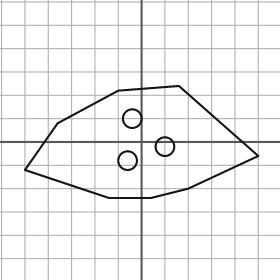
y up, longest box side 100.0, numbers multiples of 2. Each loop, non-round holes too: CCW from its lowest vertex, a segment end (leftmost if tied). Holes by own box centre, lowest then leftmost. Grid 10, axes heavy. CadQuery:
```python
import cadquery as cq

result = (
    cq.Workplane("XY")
    .moveTo(-14.0, -24.0)
    .lineTo(4.0, -24.0)
    .lineTo(20.0, -20.0)
    .lineTo(50.0, -6.0)
    .lineTo(16.0, 24.0)
    .lineTo(-10.0, 22.0)
    .lineTo(-36.0, 8.0)
    .lineTo(-50.0, -12.0)
    .close()
    .moveTo(-6.0, -8.0)
    .circle(4.0)
    .moveTo(10.0, -2.0)
    .circle(4.0)
    .moveTo(-4.0, 10.0)
    .circle(4.0)
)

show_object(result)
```